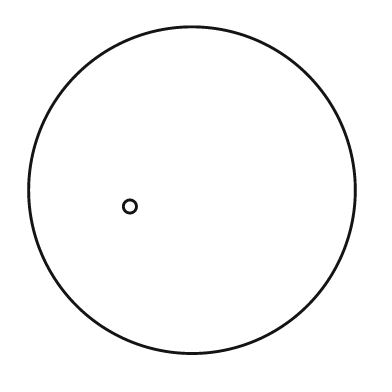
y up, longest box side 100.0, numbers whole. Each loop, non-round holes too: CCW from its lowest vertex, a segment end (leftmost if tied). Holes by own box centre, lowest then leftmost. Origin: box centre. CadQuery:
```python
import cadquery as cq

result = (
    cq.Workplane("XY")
    .moveTo(0.0, 0.0)
    .circle(50.0)
    .moveTo(-19.0, -5.0)
    .circle(2.0)
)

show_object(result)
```